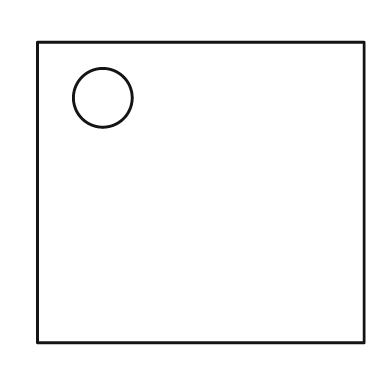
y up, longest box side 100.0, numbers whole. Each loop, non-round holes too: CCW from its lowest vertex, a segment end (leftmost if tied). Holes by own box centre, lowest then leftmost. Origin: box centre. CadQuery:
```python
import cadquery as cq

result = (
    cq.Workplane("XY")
    .moveTo(-50.0, -46.0)
    .lineTo(50.0, -46.0)
    .lineTo(50.0, 46.0)
    .lineTo(-50.0, 46.0)
    .close()
    .moveTo(-30.0, 29.0)
    .circle(9.0)
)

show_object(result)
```